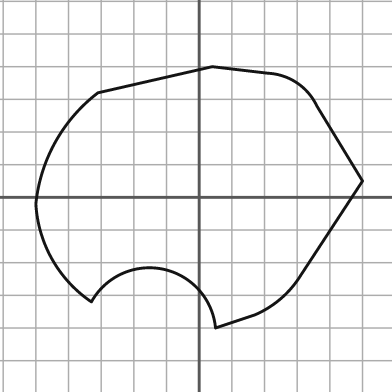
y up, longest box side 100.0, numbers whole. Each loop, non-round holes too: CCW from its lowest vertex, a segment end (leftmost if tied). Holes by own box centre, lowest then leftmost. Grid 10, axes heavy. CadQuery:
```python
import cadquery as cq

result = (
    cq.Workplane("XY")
    .moveTo(5.0, -40.0)
    .lineTo(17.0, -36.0)
    .threePointArc((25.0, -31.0), (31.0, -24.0))
    .lineTo(50.0, 5.0)
    .lineTo(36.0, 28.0)
    .threePointArc((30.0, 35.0), (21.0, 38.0))
    .lineTo(4.0, 40.0)
    .lineTo(-31.0, 32.0)
    .threePointArc((-44.0, 17.0), (-50.0, -2.0))
    .threePointArc((-45.0, -19.0), (-33.0, -32.0))
    .threePointArc((-11.0, -22.0), (5.0, -40.0))
    .close()
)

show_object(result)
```